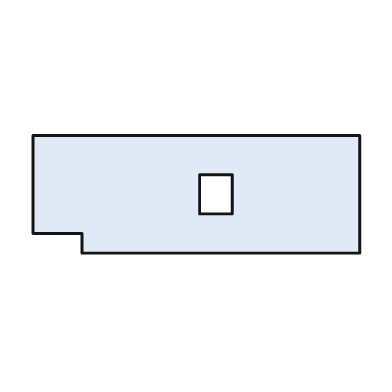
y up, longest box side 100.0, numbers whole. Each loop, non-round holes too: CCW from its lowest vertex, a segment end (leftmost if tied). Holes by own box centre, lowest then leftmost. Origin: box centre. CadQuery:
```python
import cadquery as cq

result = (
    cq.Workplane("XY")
    .moveTo(-35.0, -18.0)
    .lineTo(50.0, -18.0)
    .lineTo(50.0, 18.0)
    .lineTo(-50.0, 18.0)
    .lineTo(-50.0, -12.0)
    .lineTo(-35.0, -12.0)
    .close()
    .moveTo(1.0, -6.0)
    .lineTo(11.0, -6.0)
    .lineTo(11.0, 6.0)
    .lineTo(1.0, 6.0)
    .close()
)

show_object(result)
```